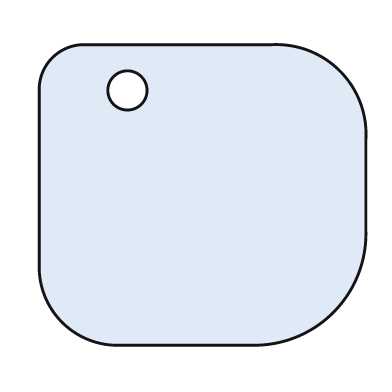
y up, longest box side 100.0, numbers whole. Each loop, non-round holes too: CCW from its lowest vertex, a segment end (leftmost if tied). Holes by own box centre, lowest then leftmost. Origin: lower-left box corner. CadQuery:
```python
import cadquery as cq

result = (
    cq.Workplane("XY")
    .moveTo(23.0, 0.0)
    .lineTo(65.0, 0.0)
    .threePointArc((90.0, 10.0), (100.0, 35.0))
    .lineTo(100.0, 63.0)
    .threePointArc((92.0, 84.0), (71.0, 92.0))
    .lineTo(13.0, 92.0)
    .threePointArc((4.0, 88.0), (0.0, 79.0))
    .lineTo(0.0, 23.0)
    .threePointArc((7.0, 7.0), (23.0, 0.0))
    .close()
    .moveTo(27.0, 78.0)
    .circle(6.0)
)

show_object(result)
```